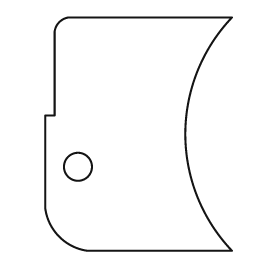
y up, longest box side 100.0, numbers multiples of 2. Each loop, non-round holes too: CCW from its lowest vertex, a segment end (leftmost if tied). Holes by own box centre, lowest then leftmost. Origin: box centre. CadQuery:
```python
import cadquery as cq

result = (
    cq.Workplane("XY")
    .moveTo(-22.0, -50.0)
    .lineTo(40.0, -50.0)
    .threePointArc((20.0, 0.0), (40.0, 50.0))
    .lineTo(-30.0, 50.0)
    .threePointArc((-34.0, 48.0), (-36.0, 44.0))
    .lineTo(-36.0, 8.0)
    .lineTo(-40.0, 8.0)
    .lineTo(-40.0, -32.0)
    .threePointArc((-34.0, -44.0), (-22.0, -50.0))
    .close()
    .moveTo(-26.0, -14.0)
    .circle(6.0)
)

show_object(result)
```